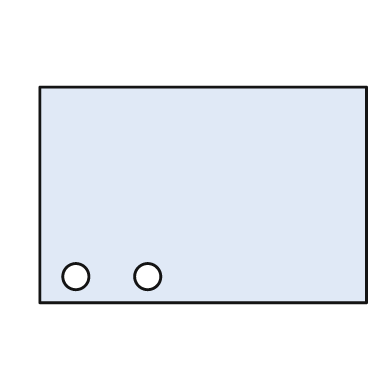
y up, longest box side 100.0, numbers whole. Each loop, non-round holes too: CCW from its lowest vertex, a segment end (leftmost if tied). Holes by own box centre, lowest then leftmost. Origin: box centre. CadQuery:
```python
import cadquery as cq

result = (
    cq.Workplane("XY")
    .moveTo(-50.0, -33.0)
    .lineTo(50.0, -33.0)
    .lineTo(50.0, 33.0)
    .lineTo(-50.0, 33.0)
    .close()
    .moveTo(-39.0, -25.0)
    .circle(4.0)
    .moveTo(-17.0, -25.0)
    .circle(4.0)
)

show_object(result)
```